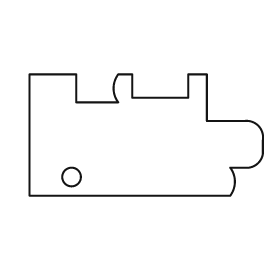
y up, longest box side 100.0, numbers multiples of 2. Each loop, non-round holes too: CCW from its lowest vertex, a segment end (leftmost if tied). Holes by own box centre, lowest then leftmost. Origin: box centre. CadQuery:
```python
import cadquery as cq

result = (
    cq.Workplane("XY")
    .moveTo(-50.0, -26.0)
    .lineTo(36.0, -26.0)
    .threePointArc((38.0, -20.0), (36.0, -14.0))
    .lineTo(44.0, -14.0)
    .threePointArc((48.0, -12.0), (50.0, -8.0))
    .lineTo(50.0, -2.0)
    .threePointArc((48.0, 4.0), (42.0, 6.0))
    .lineTo(26.0, 6.0)
    .lineTo(26.0, 26.0)
    .lineTo(18.0, 26.0)
    .lineTo(18.0, 16.0)
    .lineTo(-6.0, 16.0)
    .lineTo(-6.0, 26.0)
    .lineTo(-12.0, 26.0)
    .threePointArc((-14.0, 20.0), (-12.0, 14.0))
    .lineTo(-30.0, 14.0)
    .lineTo(-30.0, 26.0)
    .lineTo(-50.0, 26.0)
    .close()
    .moveTo(-32.0, -18.0)
    .circle(4.0)
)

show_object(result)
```